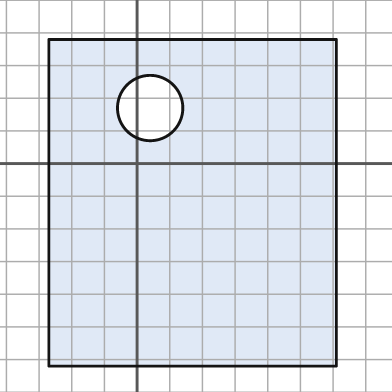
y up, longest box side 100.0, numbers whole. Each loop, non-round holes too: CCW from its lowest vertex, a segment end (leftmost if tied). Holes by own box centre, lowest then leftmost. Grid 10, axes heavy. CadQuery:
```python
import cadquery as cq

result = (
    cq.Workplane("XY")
    .moveTo(-27.0, -62.0)
    .lineTo(61.0, -62.0)
    .lineTo(61.0, 38.0)
    .lineTo(-27.0, 38.0)
    .close()
    .moveTo(4.0, 17.0)
    .circle(10.0)
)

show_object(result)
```